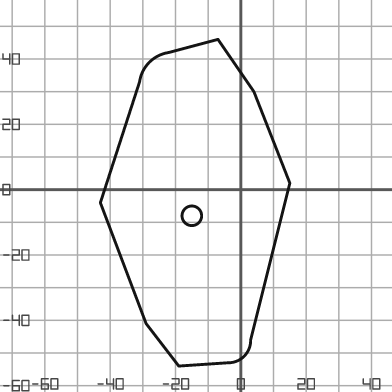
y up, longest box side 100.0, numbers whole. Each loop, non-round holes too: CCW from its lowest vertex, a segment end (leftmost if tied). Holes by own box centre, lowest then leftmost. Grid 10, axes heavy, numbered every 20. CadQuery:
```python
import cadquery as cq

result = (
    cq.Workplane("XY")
    .moveTo(-19.0, -54.0)
    .lineTo(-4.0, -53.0)
    .threePointArc((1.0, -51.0), (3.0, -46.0))
    .lineTo(15.0, 2.0)
    .lineTo(4.0, 30.0)
    .lineTo(-7.0, 46.0)
    .lineTo(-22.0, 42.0)
    .threePointArc((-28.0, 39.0), (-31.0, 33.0))
    .lineTo(-43.0, -4.0)
    .lineTo(-29.0, -41.0)
    .close()
    .moveTo(-15.0, -8.0)
    .circle(3.0)
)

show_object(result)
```